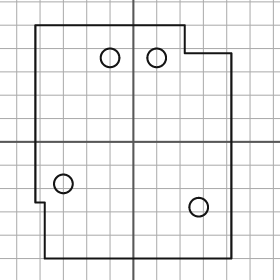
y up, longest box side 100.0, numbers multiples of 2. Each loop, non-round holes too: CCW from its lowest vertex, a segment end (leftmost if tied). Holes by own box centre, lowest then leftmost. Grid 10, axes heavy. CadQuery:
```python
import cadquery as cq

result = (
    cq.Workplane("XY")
    .moveTo(-38.0, -50.0)
    .lineTo(42.0, -50.0)
    .lineTo(42.0, 38.0)
    .lineTo(22.0, 38.0)
    .lineTo(22.0, 50.0)
    .lineTo(-42.0, 50.0)
    .lineTo(-42.0, -26.0)
    .lineTo(-38.0, -26.0)
    .close()
    .moveTo(28.0, -28.0)
    .circle(4.0)
    .moveTo(-30.0, -18.0)
    .circle(4.0)
    .moveTo(-10.0, 36.0)
    .circle(4.0)
    .moveTo(10.0, 36.0)
    .circle(4.0)
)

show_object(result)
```